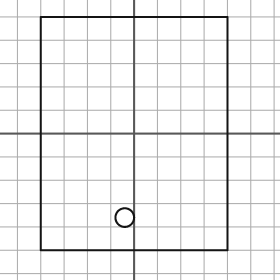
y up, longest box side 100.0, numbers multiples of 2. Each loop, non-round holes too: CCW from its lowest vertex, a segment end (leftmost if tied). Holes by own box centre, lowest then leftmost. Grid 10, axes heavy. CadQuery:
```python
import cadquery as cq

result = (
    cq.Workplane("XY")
    .moveTo(-40.0, -50.0)
    .lineTo(40.0, -50.0)
    .lineTo(40.0, 50.0)
    .lineTo(-40.0, 50.0)
    .close()
    .moveTo(-4.0, -36.0)
    .circle(4.0)
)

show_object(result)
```